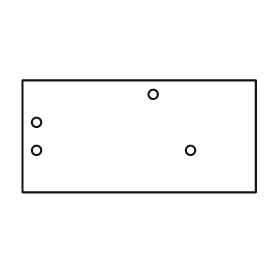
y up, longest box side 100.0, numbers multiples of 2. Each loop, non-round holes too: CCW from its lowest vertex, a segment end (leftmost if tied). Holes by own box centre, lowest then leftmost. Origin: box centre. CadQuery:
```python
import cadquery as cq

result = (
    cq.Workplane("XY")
    .moveTo(-50.0, -24.0)
    .lineTo(50.0, -24.0)
    .lineTo(50.0, 24.0)
    .lineTo(-50.0, 24.0)
    .close()
    .moveTo(-44.0, -6.0)
    .circle(2.0)
    .moveTo(22.0, -6.0)
    .circle(2.0)
    .moveTo(-44.0, 6.0)
    .circle(2.0)
    .moveTo(6.0, 18.0)
    .circle(2.0)
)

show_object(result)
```